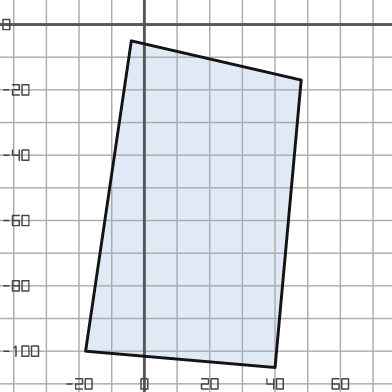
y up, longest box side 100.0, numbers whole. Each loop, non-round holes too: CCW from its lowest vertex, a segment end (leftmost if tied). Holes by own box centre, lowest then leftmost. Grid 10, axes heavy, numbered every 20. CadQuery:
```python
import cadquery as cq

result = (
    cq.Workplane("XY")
    .moveTo(40.0, -105.0)
    .lineTo(48.0, -17.0)
    .lineTo(-4.0, -5.0)
    .lineTo(-18.0, -100.0)
    .close()
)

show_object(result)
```